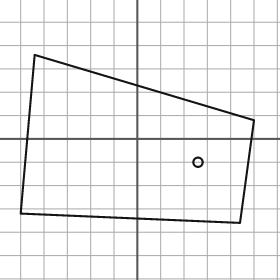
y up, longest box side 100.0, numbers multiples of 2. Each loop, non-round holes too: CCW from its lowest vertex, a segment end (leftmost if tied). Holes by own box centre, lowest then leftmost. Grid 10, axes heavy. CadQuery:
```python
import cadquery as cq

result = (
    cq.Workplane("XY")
    .moveTo(44.0, -36.0)
    .lineTo(50.0, 8.0)
    .lineTo(-44.0, 36.0)
    .lineTo(-50.0, -32.0)
    .close()
    .moveTo(26.0, -10.0)
    .circle(2.0)
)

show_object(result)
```